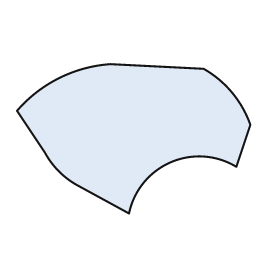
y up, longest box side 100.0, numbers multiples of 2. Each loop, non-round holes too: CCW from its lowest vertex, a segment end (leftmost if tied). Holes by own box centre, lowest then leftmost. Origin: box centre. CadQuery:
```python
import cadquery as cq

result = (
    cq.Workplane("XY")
    .moveTo(-2.0, -32.0)
    .threePointArc((16.0, -10.0), (44.0, -12.0))
    .lineTo(50.0, 6.0)
    .threePointArc((42.0, 20.0), (30.0, 30.0))
    .lineTo(-10.0, 32.0)
    .threePointArc((-32.0, 26.0), (-50.0, 12.0))
    .lineTo(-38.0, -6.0)
    .threePointArc((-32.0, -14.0), (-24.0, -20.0))
    .close()
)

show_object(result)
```